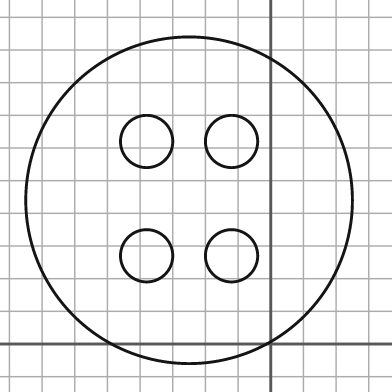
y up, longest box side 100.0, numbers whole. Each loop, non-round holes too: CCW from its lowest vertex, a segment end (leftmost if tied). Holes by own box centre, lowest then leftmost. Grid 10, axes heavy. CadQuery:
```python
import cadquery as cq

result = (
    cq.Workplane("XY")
    .moveTo(-25.0, 44.0)
    .circle(50.0)
    .moveTo(-38.0, 27.0)
    .circle(8.0)
    .moveTo(-12.0, 27.0)
    .circle(8.0)
    .moveTo(-38.0, 62.0)
    .circle(8.0)
    .moveTo(-12.0, 62.0)
    .circle(8.0)
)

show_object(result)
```